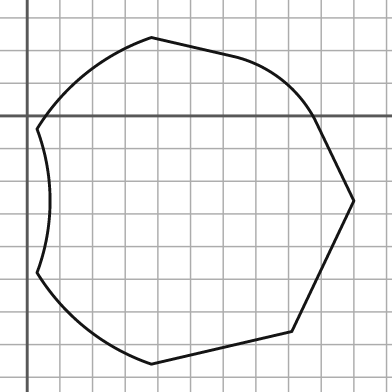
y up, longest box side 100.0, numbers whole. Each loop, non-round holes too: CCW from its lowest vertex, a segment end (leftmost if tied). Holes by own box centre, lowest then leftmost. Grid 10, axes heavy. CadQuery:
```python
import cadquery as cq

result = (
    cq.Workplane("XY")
    .moveTo(38.0, -76.0)
    .lineTo(81.0, -66.0)
    .lineTo(100.0, -26.0)
    .lineTo(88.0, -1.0)
    .threePointArc((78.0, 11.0), (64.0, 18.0))
    .lineTo(38.0, 24.0)
    .threePointArc((18.0, 13.0), (3.0, -4.0))
    .threePointArc((7.0, -26.0), (3.0, -48.0))
    .threePointArc((18.0, -65.0), (38.0, -76.0))
    .close()
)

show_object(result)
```